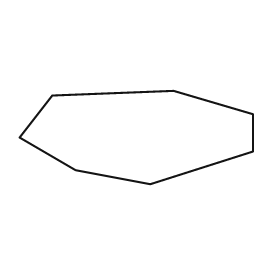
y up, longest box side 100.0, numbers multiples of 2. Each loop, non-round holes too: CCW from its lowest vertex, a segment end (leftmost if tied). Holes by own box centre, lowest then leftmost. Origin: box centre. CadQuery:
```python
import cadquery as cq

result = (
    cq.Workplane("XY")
    .moveTo(6.0, -20.0)
    .lineTo(50.0, -6.0)
    .lineTo(50.0, 10.0)
    .lineTo(16.0, 20.0)
    .lineTo(-36.0, 18.0)
    .lineTo(-50.0, 0.0)
    .lineTo(-26.0, -14.0)
    .close()
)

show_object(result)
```